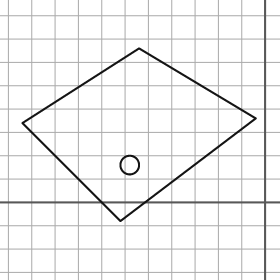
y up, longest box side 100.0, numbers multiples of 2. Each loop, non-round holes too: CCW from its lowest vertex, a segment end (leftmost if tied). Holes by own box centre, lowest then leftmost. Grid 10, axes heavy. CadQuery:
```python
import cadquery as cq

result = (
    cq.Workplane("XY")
    .moveTo(-62.0, -8.0)
    .lineTo(-4.0, 36.0)
    .lineTo(-54.0, 66.0)
    .lineTo(-104.0, 34.0)
    .close()
    .moveTo(-58.0, 16.0)
    .circle(4.0)
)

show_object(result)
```